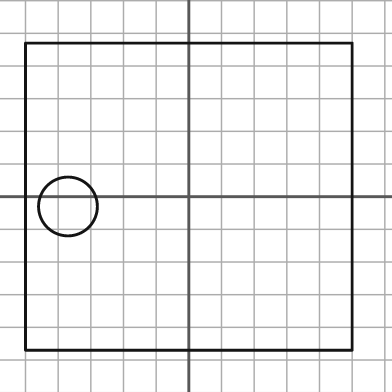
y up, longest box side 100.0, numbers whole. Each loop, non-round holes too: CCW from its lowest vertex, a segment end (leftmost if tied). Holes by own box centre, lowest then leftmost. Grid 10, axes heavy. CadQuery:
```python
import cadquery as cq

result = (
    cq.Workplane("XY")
    .moveTo(-50.0, -47.0)
    .lineTo(50.0, -47.0)
    .lineTo(50.0, 47.0)
    .lineTo(-50.0, 47.0)
    .close()
    .moveTo(-37.0, -3.0)
    .circle(9.0)
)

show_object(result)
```